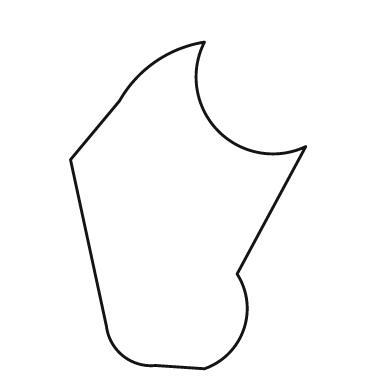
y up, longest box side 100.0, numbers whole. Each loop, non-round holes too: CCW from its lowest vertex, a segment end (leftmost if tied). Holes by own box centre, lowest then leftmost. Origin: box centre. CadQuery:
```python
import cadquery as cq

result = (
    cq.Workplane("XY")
    .moveTo(5.0, -50.0)
    .threePointArc((17.0, -38.0), (15.0, -21.0))
    .lineTo(36.0, 18.0)
    .threePointArc((9.0, 23.0), (5.0, 50.0))
    .threePointArc((-10.0, 44.0), (-21.0, 32.0))
    .lineTo(-36.0, 14.0)
    .lineTo(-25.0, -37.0)
    .threePointArc((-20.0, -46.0), (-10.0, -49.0))
    .close()
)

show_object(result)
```